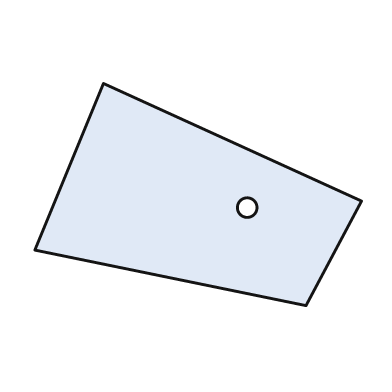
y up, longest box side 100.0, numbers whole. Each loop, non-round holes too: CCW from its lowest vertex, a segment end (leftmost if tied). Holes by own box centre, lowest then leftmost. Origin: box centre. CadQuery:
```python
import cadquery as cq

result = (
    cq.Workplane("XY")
    .moveTo(33.0, -34.0)
    .lineTo(50.0, -2.0)
    .lineTo(-29.0, 34.0)
    .lineTo(-50.0, -17.0)
    .close()
    .moveTo(15.0, -4.0)
    .circle(3.0)
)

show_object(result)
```